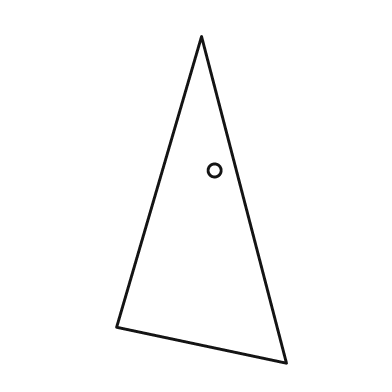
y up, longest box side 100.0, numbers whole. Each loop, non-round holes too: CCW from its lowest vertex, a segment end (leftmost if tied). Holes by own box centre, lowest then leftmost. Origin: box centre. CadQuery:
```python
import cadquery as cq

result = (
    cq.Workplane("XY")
    .moveTo(26.0, -50.0)
    .lineTo(0.0, 50.0)
    .lineTo(-26.0, -39.0)
    .close()
    .moveTo(4.0, 9.0)
    .circle(2.0)
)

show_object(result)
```